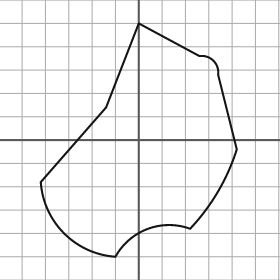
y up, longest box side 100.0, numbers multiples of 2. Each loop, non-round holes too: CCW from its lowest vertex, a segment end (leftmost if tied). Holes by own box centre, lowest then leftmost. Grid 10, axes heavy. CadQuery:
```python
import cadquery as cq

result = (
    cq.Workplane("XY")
    .moveTo(-10.0, -50.0)
    .threePointArc((4.0, -38.0), (22.0, -38.0))
    .threePointArc((34.0, -22.0), (42.0, -4.0))
    .lineTo(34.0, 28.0)
    .threePointArc((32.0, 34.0), (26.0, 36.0))
    .lineTo(0.0, 50.0)
    .lineTo(-14.0, 14.0)
    .lineTo(-42.0, -18.0)
    .threePointArc((-32.0, -40.0), (-10.0, -50.0))
    .close()
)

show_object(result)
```